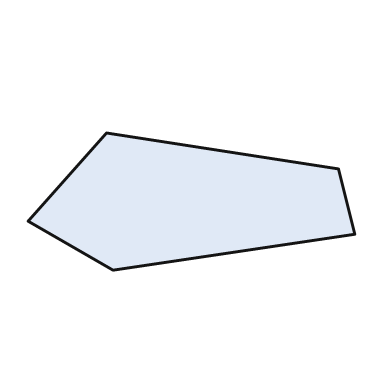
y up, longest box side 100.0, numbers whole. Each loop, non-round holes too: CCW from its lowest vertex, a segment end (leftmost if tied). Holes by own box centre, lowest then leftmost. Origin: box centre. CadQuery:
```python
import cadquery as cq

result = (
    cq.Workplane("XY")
    .moveTo(-24.0, -21.0)
    .lineTo(50.0, -10.0)
    .lineTo(45.0, 10.0)
    .lineTo(-26.0, 21.0)
    .lineTo(-50.0, -6.0)
    .close()
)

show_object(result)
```